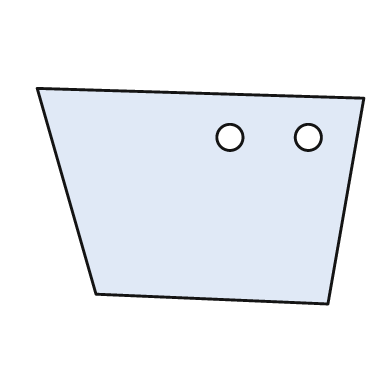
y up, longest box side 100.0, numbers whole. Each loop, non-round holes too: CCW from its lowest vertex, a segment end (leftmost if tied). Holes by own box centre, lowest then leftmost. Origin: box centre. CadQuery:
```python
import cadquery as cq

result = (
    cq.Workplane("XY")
    .moveTo(39.0, -33.0)
    .lineTo(50.0, 30.0)
    .lineTo(-50.0, 33.0)
    .lineTo(-32.0, -30.0)
    .close()
    .moveTo(9.0, 18.0)
    .circle(4.0)
    .moveTo(33.0, 18.0)
    .circle(4.0)
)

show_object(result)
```